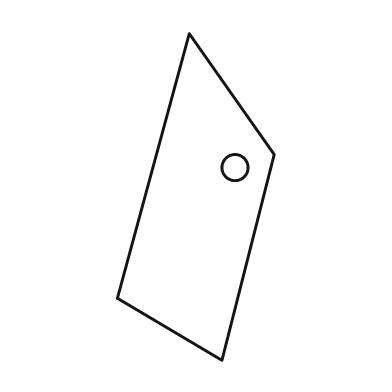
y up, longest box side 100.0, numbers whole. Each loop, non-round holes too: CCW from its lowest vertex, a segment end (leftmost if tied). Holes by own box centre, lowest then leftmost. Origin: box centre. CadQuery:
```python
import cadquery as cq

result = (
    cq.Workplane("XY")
    .moveTo(8.0, -50.0)
    .lineTo(24.0, 13.0)
    .lineTo(-2.0, 50.0)
    .lineTo(-24.0, -31.0)
    .close()
    .moveTo(12.0, 9.0)
    .circle(4.0)
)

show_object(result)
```